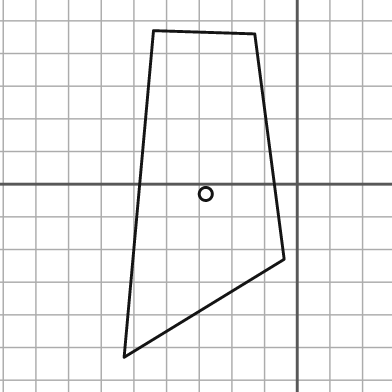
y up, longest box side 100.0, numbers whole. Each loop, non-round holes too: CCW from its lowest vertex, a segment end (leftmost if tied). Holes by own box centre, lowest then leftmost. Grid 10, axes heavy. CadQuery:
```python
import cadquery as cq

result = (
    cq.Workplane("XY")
    .moveTo(-53.0, -53.0)
    .lineTo(-4.0, -23.0)
    .lineTo(-13.0, 46.0)
    .lineTo(-44.0, 47.0)
    .close()
    .moveTo(-28.0, -3.0)
    .circle(2.0)
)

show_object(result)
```